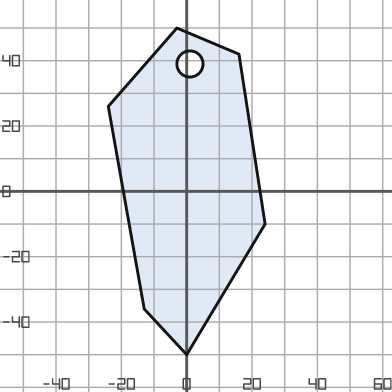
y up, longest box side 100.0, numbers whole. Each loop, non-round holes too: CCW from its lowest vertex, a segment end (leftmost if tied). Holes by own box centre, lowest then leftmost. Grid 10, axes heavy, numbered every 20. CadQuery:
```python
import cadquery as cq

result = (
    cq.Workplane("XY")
    .moveTo(0.0, -50.0)
    .lineTo(24.0, -10.0)
    .lineTo(16.0, 42.0)
    .lineTo(-3.0, 50.0)
    .lineTo(-24.0, 26.0)
    .lineTo(-13.0, -36.0)
    .close()
    .moveTo(1.0, 39.0)
    .circle(4.0)
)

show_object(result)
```